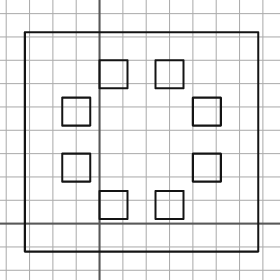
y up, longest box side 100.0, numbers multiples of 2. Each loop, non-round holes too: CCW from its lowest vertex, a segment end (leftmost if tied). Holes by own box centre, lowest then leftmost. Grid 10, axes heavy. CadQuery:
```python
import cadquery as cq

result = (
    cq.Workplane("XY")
    .moveTo(-32.0, -12.0)
    .lineTo(68.0, -12.0)
    .lineTo(68.0, 82.0)
    .lineTo(-32.0, 82.0)
    .close()
    .moveTo(0.0, 2.0)
    .lineTo(12.0, 2.0)
    .lineTo(12.0, 14.0)
    .lineTo(0.0, 14.0)
    .close()
    .moveTo(24.0, 2.0)
    .lineTo(36.0, 2.0)
    .lineTo(36.0, 14.0)
    .lineTo(24.0, 14.0)
    .close()
    .moveTo(-16.0, 18.0)
    .lineTo(-4.0, 18.0)
    .lineTo(-4.0, 30.0)
    .lineTo(-16.0, 30.0)
    .close()
    .moveTo(40.0, 18.0)
    .lineTo(52.0, 18.0)
    .lineTo(52.0, 30.0)
    .lineTo(40.0, 30.0)
    .close()
    .moveTo(-16.0, 42.0)
    .lineTo(-4.0, 42.0)
    .lineTo(-4.0, 54.0)
    .lineTo(-16.0, 54.0)
    .close()
    .moveTo(40.0, 42.0)
    .lineTo(52.0, 42.0)
    .lineTo(52.0, 54.0)
    .lineTo(40.0, 54.0)
    .close()
    .moveTo(0.0, 58.0)
    .lineTo(12.0, 58.0)
    .lineTo(12.0, 70.0)
    .lineTo(0.0, 70.0)
    .close()
    .moveTo(24.0, 58.0)
    .lineTo(36.0, 58.0)
    .lineTo(36.0, 70.0)
    .lineTo(24.0, 70.0)
    .close()
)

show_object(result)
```